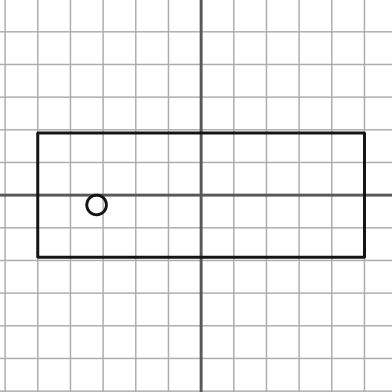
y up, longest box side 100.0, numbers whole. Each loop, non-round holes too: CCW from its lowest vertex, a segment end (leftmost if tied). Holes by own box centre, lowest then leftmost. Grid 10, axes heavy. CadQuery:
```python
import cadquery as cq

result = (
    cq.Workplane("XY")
    .moveTo(-50.0, -19.0)
    .lineTo(50.0, -19.0)
    .lineTo(50.0, 19.0)
    .lineTo(-50.0, 19.0)
    .close()
    .moveTo(-32.0, -3.0)
    .circle(3.0)
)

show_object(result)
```